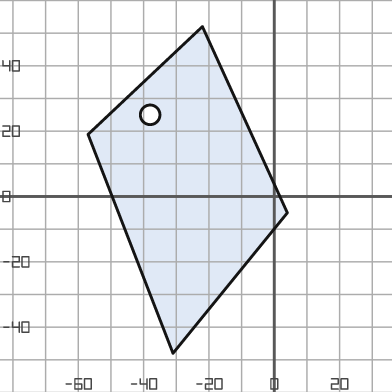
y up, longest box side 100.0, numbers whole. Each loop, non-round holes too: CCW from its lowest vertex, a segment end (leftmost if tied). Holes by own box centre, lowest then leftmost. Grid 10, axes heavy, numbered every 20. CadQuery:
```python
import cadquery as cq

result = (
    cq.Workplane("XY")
    .moveTo(-31.0, -48.0)
    .lineTo(4.0, -5.0)
    .lineTo(-22.0, 52.0)
    .lineTo(-57.0, 19.0)
    .close()
    .moveTo(-38.0, 25.0)
    .circle(3.0)
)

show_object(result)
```